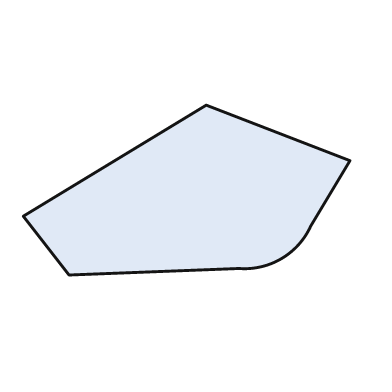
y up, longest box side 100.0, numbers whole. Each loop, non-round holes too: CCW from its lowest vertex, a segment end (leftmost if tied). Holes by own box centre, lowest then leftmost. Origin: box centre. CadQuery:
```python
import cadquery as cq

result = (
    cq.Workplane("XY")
    .moveTo(-36.0, -26.0)
    .lineTo(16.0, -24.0)
    .threePointArc((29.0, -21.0), (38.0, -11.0))
    .lineTo(50.0, 9.0)
    .lineTo(6.0, 26.0)
    .lineTo(-50.0, -8.0)
    .close()
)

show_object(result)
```